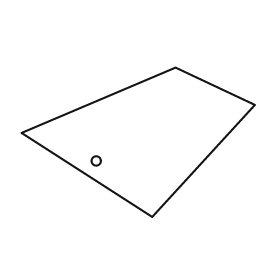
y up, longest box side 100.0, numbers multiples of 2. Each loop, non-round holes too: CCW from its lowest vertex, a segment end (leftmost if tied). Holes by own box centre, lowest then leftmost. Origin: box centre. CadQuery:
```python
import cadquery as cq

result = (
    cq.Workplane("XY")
    .moveTo(6.0, -32.0)
    .lineTo(50.0, 16.0)
    .lineTo(16.0, 32.0)
    .lineTo(-50.0, 4.0)
    .close()
    .moveTo(-18.0, -8.0)
    .circle(2.0)
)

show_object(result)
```